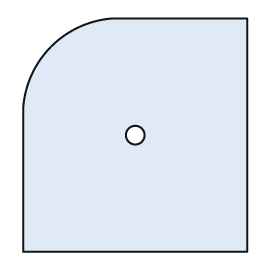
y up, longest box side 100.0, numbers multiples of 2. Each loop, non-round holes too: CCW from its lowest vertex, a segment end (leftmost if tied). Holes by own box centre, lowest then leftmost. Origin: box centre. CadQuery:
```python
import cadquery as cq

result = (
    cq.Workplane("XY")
    .moveTo(-48.0, -50.0)
    .lineTo(48.0, -50.0)
    .lineTo(48.0, 50.0)
    .lineTo(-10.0, 50.0)
    .threePointArc((-36.0, 38.0), (-48.0, 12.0))
    .close()
    .moveTo(0.0, 0.0)
    .circle(4.0)
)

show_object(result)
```